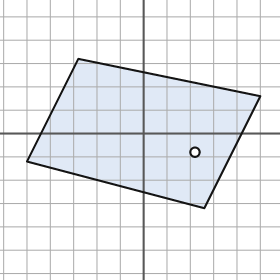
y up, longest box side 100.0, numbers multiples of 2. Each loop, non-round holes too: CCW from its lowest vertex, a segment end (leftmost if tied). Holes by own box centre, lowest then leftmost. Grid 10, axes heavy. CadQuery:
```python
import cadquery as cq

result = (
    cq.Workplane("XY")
    .moveTo(26.0, -32.0)
    .lineTo(50.0, 16.0)
    .lineTo(-28.0, 32.0)
    .lineTo(-50.0, -12.0)
    .close()
    .moveTo(22.0, -8.0)
    .circle(2.0)
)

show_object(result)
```